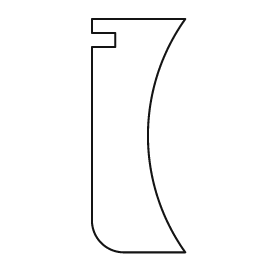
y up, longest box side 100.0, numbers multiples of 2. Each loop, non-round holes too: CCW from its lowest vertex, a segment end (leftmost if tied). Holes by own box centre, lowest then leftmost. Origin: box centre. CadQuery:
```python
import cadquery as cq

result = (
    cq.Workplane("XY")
    .moveTo(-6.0, -50.0)
    .lineTo(20.0, -50.0)
    .threePointArc((4.0, 0.0), (20.0, 50.0))
    .lineTo(-20.0, 50.0)
    .lineTo(-20.0, 44.0)
    .lineTo(-10.0, 44.0)
    .lineTo(-10.0, 38.0)
    .lineTo(-20.0, 38.0)
    .lineTo(-20.0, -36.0)
    .threePointArc((-16.0, -46.0), (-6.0, -50.0))
    .close()
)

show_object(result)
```